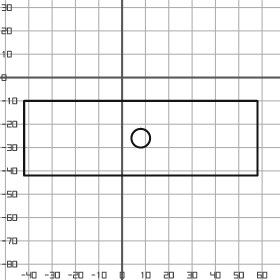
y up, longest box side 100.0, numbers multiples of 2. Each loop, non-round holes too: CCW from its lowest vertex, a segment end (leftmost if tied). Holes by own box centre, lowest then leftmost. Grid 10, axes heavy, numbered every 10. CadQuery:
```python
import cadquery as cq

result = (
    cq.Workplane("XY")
    .moveTo(-42.0, -42.0)
    .lineTo(58.0, -42.0)
    .lineTo(58.0, -10.0)
    .lineTo(-42.0, -10.0)
    .close()
    .moveTo(8.0, -26.0)
    .circle(4.0)
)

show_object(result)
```